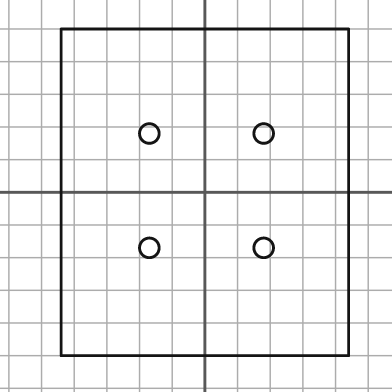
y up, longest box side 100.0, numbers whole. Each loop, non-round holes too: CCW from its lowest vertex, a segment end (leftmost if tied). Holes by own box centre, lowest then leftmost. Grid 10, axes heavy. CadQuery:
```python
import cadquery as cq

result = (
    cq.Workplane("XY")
    .moveTo(-44.0, -50.0)
    .lineTo(44.0, -50.0)
    .lineTo(44.0, 50.0)
    .lineTo(-44.0, 50.0)
    .close()
    .moveTo(-17.0, -17.0)
    .circle(3.0)
    .moveTo(18.0, -17.0)
    .circle(3.0)
    .moveTo(-17.0, 18.0)
    .circle(3.0)
    .moveTo(18.0, 18.0)
    .circle(3.0)
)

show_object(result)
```